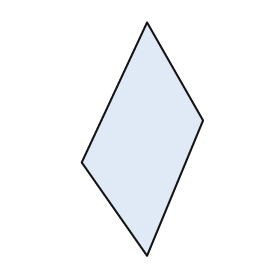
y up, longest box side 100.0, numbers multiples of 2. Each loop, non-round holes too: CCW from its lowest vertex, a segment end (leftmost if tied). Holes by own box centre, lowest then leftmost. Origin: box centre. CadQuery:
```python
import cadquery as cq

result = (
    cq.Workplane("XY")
    .moveTo(2.0, -50.0)
    .lineTo(26.0, 8.0)
    .lineTo(2.0, 50.0)
    .lineTo(-26.0, -10.0)
    .close()
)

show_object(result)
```